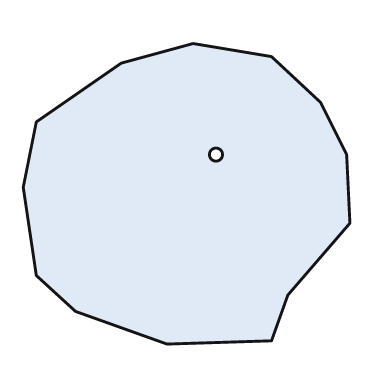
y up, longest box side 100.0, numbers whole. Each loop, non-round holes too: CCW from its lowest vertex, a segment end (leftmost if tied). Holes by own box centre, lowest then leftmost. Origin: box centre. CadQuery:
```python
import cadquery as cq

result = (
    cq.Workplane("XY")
    .moveTo(-6.0, -46.0)
    .lineTo(26.0, -45.0)
    .lineTo(31.0, -31.0)
    .lineTo(50.0, -9.0)
    .lineTo(49.0, 12.0)
    .lineTo(41.0, 28.0)
    .lineTo(26.0, 42.0)
    .lineTo(2.0, 46.0)
    .lineTo(-20.0, 40.0)
    .lineTo(-46.0, 22.0)
    .lineTo(-50.0, 2.0)
    .lineTo(-46.0, -25.0)
    .lineTo(-34.0, -36.0)
    .close()
    .moveTo(9.0, 12.0)
    .circle(2.0)
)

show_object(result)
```